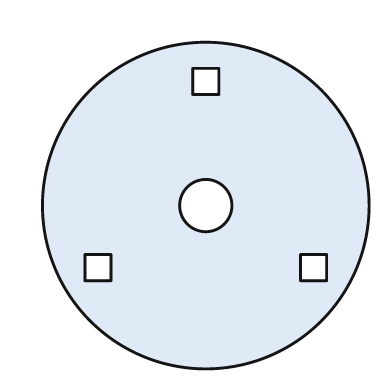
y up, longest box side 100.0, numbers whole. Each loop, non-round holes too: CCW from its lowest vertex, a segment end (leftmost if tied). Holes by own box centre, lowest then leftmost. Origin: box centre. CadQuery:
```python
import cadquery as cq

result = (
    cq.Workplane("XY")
    .moveTo(0.0, 0.0)
    .circle(50.0)
    .moveTo(-37.0, -23.0)
    .lineTo(-29.0, -23.0)
    .lineTo(-29.0, -15.0)
    .lineTo(-37.0, -15.0)
    .close()
    .moveTo(29.0, -23.0)
    .lineTo(37.0, -23.0)
    .lineTo(37.0, -15.0)
    .lineTo(29.0, -15.0)
    .close()
    .moveTo(0.0, 0.0)
    .circle(8.0)
    .moveTo(-4.0, 34.0)
    .lineTo(4.0, 34.0)
    .lineTo(4.0, 42.0)
    .lineTo(-4.0, 42.0)
    .close()
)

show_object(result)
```